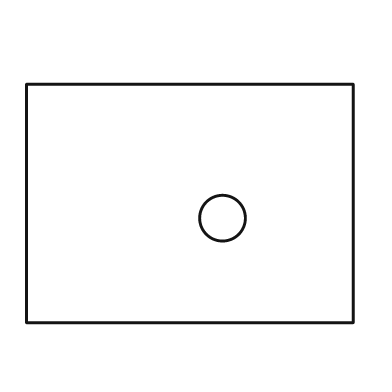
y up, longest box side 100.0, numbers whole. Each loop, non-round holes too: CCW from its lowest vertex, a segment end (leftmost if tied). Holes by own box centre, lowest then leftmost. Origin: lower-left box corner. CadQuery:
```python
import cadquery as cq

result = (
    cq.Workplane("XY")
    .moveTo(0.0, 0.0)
    .lineTo(100.0, 0.0)
    .lineTo(100.0, 73.0)
    .lineTo(0.0, 73.0)
    .close()
    .moveTo(60.0, 32.0)
    .circle(7.0)
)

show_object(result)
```